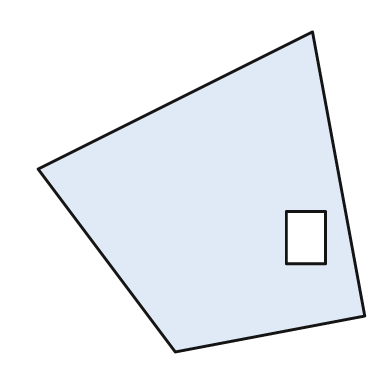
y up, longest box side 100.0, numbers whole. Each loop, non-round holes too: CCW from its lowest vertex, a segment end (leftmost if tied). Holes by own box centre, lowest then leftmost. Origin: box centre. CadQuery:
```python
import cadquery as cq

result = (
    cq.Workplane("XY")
    .moveTo(-8.0, -49.0)
    .lineTo(50.0, -38.0)
    .lineTo(34.0, 49.0)
    .lineTo(-50.0, 7.0)
    .close()
    .moveTo(26.0, -22.0)
    .lineTo(38.0, -22.0)
    .lineTo(38.0, -6.0)
    .lineTo(26.0, -6.0)
    .close()
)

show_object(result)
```